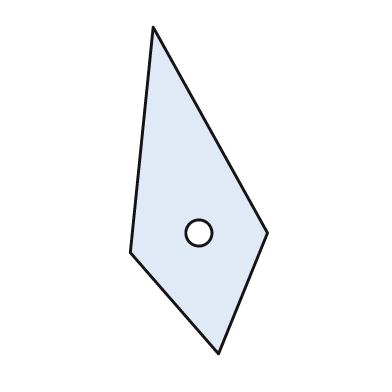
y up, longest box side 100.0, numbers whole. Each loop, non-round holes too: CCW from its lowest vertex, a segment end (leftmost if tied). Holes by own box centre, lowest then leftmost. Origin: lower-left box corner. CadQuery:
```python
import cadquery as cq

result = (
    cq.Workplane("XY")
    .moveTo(27.0, 0.0)
    .lineTo(42.0, 37.0)
    .lineTo(7.0, 100.0)
    .lineTo(0.0, 31.0)
    .close()
    .moveTo(21.0, 37.0)
    .circle(4.0)
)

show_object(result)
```